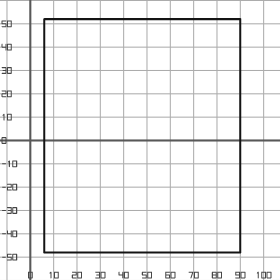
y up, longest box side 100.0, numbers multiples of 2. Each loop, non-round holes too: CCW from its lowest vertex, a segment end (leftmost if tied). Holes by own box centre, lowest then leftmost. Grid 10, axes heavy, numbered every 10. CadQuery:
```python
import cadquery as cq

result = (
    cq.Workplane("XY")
    .moveTo(6.0, -48.0)
    .lineTo(90.0, -48.0)
    .lineTo(90.0, 52.0)
    .lineTo(6.0, 52.0)
    .close()
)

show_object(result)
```